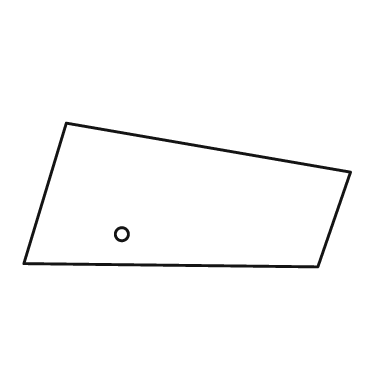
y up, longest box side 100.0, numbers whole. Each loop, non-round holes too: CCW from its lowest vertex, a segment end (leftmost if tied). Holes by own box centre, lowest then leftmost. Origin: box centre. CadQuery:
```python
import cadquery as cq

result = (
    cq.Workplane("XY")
    .moveTo(40.0, -22.0)
    .lineTo(50.0, 7.0)
    .lineTo(-37.0, 22.0)
    .lineTo(-50.0, -21.0)
    .close()
    .moveTo(-20.0, -12.0)
    .circle(2.0)
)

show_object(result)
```